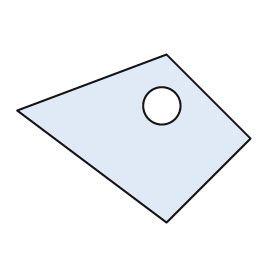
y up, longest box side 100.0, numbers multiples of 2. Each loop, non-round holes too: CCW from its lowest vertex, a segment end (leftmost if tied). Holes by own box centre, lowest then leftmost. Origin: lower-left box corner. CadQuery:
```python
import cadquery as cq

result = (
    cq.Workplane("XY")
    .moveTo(64.0, 0.0)
    .lineTo(100.0, 36.0)
    .lineTo(64.0, 72.0)
    .lineTo(0.0, 48.0)
    .close()
    .moveTo(62.0, 50.0)
    .circle(8.0)
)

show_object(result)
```